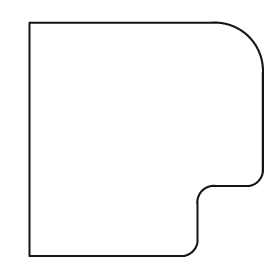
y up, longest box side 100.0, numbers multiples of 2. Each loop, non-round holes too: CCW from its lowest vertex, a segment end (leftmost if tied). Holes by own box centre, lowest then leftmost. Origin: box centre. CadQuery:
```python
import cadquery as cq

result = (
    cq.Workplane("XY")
    .moveTo(-50.0, -50.0)
    .lineTo(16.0, -50.0)
    .threePointArc((20.0, -48.0), (22.0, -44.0))
    .lineTo(22.0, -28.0)
    .threePointArc((24.0, -22.0), (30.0, -20.0))
    .lineTo(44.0, -20.0)
    .threePointArc((48.0, -18.0), (50.0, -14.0))
    .lineTo(50.0, 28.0)
    .threePointArc((44.0, 44.0), (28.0, 50.0))
    .lineTo(-50.0, 50.0)
    .close()
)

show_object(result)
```